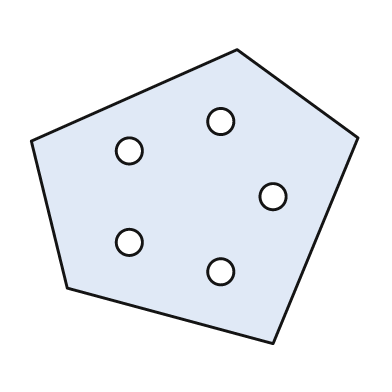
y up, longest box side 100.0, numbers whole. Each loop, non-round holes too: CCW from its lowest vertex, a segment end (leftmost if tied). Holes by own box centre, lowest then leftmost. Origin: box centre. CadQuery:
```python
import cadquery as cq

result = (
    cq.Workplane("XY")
    .moveTo(24.0, -45.0)
    .lineTo(50.0, 18.0)
    .lineTo(13.0, 45.0)
    .lineTo(-50.0, 17.0)
    .lineTo(-39.0, -28.0)
    .close()
    .moveTo(8.0, -23.0)
    .circle(4.0)
    .moveTo(-20.0, -14.0)
    .circle(4.0)
    .moveTo(24.0, 0.0)
    .circle(4.0)
    .moveTo(-20.0, 14.0)
    .circle(4.0)
    .moveTo(8.0, 23.0)
    .circle(4.0)
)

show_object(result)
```